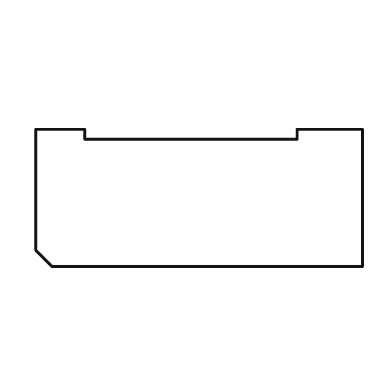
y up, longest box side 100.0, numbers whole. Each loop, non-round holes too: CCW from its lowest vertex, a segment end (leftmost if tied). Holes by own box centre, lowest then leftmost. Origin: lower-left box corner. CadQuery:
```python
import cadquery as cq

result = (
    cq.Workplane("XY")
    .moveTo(5.0, 0.0)
    .lineTo(100.0, 0.0)
    .lineTo(100.0, 42.0)
    .lineTo(80.0, 42.0)
    .lineTo(80.0, 39.0)
    .lineTo(15.0, 39.0)
    .lineTo(15.0, 42.0)
    .lineTo(0.0, 42.0)
    .lineTo(0.0, 5.0)
    .close()
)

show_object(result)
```